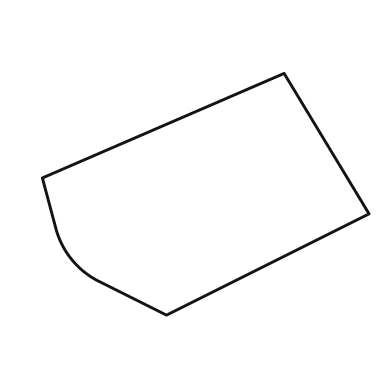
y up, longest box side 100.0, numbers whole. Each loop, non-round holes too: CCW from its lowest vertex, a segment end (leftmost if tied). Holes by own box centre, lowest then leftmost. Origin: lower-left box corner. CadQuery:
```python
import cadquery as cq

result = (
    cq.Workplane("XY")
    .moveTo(38.0, 0.0)
    .lineTo(100.0, 31.0)
    .lineTo(74.0, 74.0)
    .lineTo(0.0, 42.0)
    .lineTo(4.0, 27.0)
    .threePointArc((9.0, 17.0), (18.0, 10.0))
    .close()
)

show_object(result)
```